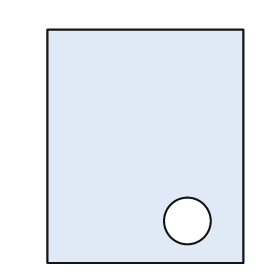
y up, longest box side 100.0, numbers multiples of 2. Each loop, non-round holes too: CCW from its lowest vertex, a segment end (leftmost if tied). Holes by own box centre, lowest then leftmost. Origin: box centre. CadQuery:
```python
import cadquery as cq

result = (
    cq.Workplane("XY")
    .moveTo(-42.0, -50.0)
    .lineTo(42.0, -50.0)
    .lineTo(42.0, 50.0)
    .lineTo(-42.0, 50.0)
    .close()
    .moveTo(18.0, -32.0)
    .circle(10.0)
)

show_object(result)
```